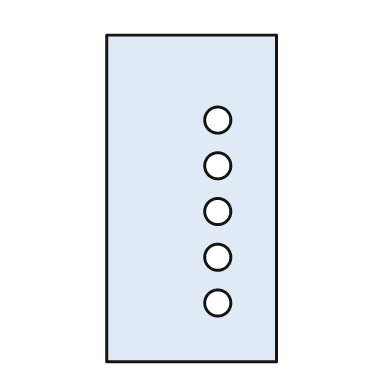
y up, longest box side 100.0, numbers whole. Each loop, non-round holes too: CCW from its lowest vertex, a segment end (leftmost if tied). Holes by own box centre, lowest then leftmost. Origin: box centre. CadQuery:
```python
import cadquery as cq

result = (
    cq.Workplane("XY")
    .moveTo(-26.0, -50.0)
    .lineTo(26.0, -50.0)
    .lineTo(26.0, 50.0)
    .lineTo(-26.0, 50.0)
    .close()
    .moveTo(8.0, -32.0)
    .circle(4.0)
    .moveTo(8.0, -18.0)
    .circle(4.0)
    .moveTo(8.0, -4.0)
    .circle(4.0)
    .moveTo(8.0, 10.0)
    .circle(4.0)
    .moveTo(8.0, 24.0)
    .circle(4.0)
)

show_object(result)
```